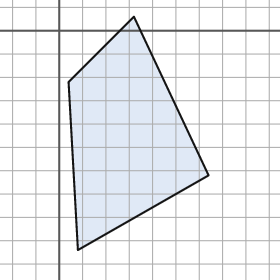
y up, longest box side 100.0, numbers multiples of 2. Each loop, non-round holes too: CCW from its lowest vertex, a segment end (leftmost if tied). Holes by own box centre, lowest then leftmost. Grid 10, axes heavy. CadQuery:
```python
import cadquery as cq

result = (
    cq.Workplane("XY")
    .moveTo(8.0, -94.0)
    .lineTo(64.0, -62.0)
    .lineTo(32.0, 6.0)
    .lineTo(4.0, -22.0)
    .close()
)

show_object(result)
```